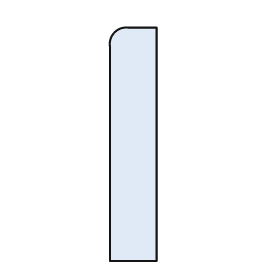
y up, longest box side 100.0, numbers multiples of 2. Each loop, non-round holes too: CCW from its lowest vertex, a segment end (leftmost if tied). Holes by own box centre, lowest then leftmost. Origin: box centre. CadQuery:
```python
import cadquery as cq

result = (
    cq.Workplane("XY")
    .moveTo(-10.0, -50.0)
    .lineTo(10.0, -50.0)
    .lineTo(10.0, 50.0)
    .lineTo(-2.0, 50.0)
    .threePointArc((-8.0, 48.0), (-10.0, 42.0))
    .close()
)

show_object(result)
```